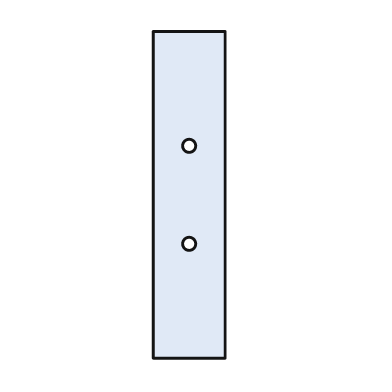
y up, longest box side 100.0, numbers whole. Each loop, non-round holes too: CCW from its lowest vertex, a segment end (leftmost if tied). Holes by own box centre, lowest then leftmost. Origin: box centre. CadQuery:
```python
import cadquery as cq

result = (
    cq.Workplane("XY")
    .moveTo(-11.0, -50.0)
    .lineTo(11.0, -50.0)
    .lineTo(11.0, 50.0)
    .lineTo(-11.0, 50.0)
    .close()
    .moveTo(0.0, -15.0)
    .circle(2.0)
    .moveTo(0.0, 15.0)
    .circle(2.0)
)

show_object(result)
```